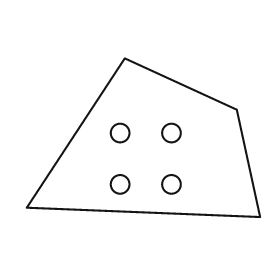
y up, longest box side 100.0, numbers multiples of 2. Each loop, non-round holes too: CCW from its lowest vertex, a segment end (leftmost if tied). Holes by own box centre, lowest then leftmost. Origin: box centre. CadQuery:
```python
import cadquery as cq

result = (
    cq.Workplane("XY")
    .moveTo(50.0, -34.0)
    .lineTo(40.0, 12.0)
    .lineTo(-8.0, 34.0)
    .lineTo(-50.0, -30.0)
    .close()
    .moveTo(-10.0, -20.0)
    .circle(4.0)
    .moveTo(12.0, -20.0)
    .circle(4.0)
    .moveTo(-10.0, 2.0)
    .circle(4.0)
    .moveTo(12.0, 2.0)
    .circle(4.0)
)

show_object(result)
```